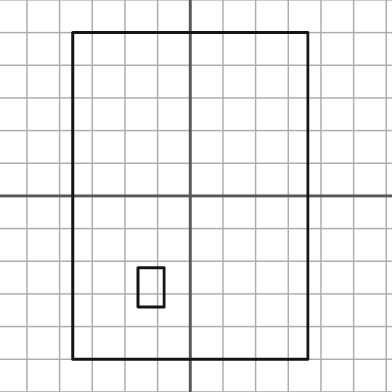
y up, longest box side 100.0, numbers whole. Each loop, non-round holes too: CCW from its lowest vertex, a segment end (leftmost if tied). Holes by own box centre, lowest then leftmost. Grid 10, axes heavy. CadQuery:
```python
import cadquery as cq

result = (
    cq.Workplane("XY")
    .moveTo(-36.0, -50.0)
    .lineTo(36.0, -50.0)
    .lineTo(36.0, 50.0)
    .lineTo(-36.0, 50.0)
    .close()
    .moveTo(-16.0, -34.0)
    .lineTo(-8.0, -34.0)
    .lineTo(-8.0, -22.0)
    .lineTo(-16.0, -22.0)
    .close()
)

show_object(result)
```